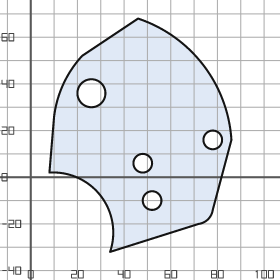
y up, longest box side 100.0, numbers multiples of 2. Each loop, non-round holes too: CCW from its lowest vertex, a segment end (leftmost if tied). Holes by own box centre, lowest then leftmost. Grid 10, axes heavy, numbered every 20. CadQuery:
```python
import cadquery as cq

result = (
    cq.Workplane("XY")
    .moveTo(34.0, -32.0)
    .lineTo(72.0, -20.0)
    .threePointArc((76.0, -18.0), (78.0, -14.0))
    .lineTo(86.0, 16.0)
    .threePointArc((74.0, 48.0), (46.0, 68.0))
    .lineTo(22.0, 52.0)
    .threePointArc((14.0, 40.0), (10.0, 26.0))
    .lineTo(8.0, 2.0)
    .threePointArc((30.0, -8.0), (34.0, -32.0))
    .close()
    .moveTo(52.0, -10.0)
    .circle(4.0)
    .moveTo(48.0, 6.0)
    .circle(4.0)
    .moveTo(78.0, 16.0)
    .circle(4.0)
    .moveTo(26.0, 36.0)
    .circle(6.0)
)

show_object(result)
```